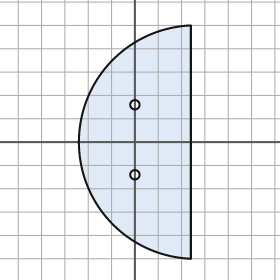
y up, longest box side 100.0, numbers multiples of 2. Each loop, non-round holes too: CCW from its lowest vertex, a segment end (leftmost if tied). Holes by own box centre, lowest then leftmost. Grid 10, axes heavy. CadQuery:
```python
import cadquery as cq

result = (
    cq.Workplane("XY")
    .moveTo(24.0, -50.0)
    .lineTo(24.0, 50.0)
    .threePointArc((-24.0, 0.0), (24.0, -50.0))
    .close()
    .moveTo(0.0, -14.0)
    .circle(2.0)
    .moveTo(0.0, 16.0)
    .circle(2.0)
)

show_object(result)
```